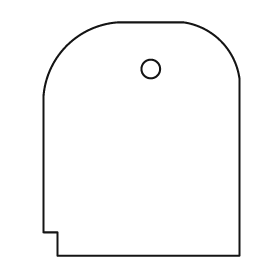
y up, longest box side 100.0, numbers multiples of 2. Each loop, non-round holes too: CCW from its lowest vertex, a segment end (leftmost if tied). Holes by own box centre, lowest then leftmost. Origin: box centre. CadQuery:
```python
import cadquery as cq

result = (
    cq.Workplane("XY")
    .moveTo(-36.0, -50.0)
    .lineTo(42.0, -50.0)
    .lineTo(42.0, 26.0)
    .threePointArc((34.0, 42.0), (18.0, 50.0))
    .lineTo(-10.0, 50.0)
    .threePointArc((-32.0, 40.0), (-42.0, 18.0))
    .lineTo(-42.0, -40.0)
    .lineTo(-36.0, -40.0)
    .close()
    .moveTo(4.0, 30.0)
    .circle(4.0)
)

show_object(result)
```